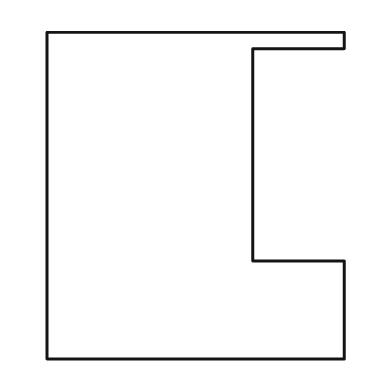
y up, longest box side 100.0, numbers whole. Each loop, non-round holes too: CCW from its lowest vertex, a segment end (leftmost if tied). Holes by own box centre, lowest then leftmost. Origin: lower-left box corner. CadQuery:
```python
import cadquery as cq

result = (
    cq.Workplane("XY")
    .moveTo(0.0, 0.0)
    .lineTo(91.0, 0.0)
    .lineTo(91.0, 30.0)
    .lineTo(63.0, 30.0)
    .lineTo(63.0, 95.0)
    .lineTo(91.0, 95.0)
    .lineTo(91.0, 100.0)
    .lineTo(0.0, 100.0)
    .close()
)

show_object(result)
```